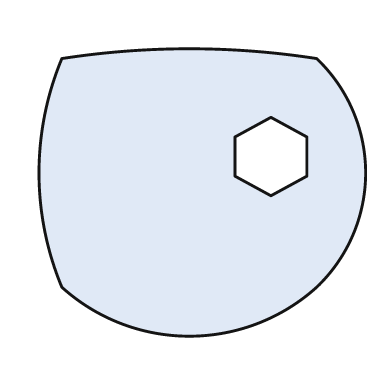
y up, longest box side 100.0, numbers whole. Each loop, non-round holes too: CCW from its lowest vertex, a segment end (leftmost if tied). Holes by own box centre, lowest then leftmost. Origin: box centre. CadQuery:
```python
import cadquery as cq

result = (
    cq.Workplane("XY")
    .moveTo(-43.0, -29.0)
    .threePointArc((-4.0, -44.0), (35.0, -29.0))
    .threePointArc((50.0, 6.0), (35.0, 41.0))
    .threePointArc((-4.0, 44.0), (-43.0, 41.0))
    .threePointArc((-50.0, 6.0), (-43.0, -29.0))
    .close()
    .moveTo(21.0, -1.0)
    .lineTo(32.0, 5.0)
    .lineTo(32.0, 17.0)
    .lineTo(21.0, 23.0)
    .lineTo(10.0, 17.0)
    .lineTo(10.0, 5.0)
    .close()
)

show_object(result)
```